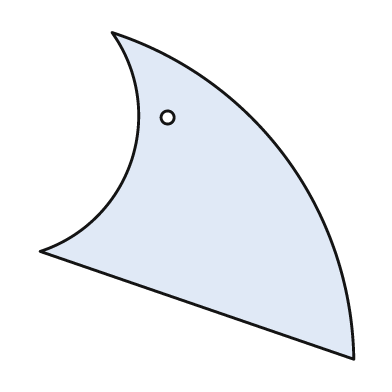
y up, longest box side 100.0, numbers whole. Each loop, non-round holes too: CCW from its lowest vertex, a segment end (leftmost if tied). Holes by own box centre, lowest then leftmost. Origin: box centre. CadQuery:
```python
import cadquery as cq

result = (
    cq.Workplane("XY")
    .moveTo(48.0, -50.0)
    .threePointArc((27.0, 12.0), (-26.0, 50.0))
    .threePointArc((-20.0, 11.0), (-48.0, -17.0))
    .close()
    .moveTo(-9.0, 24.0)
    .circle(2.0)
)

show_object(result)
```